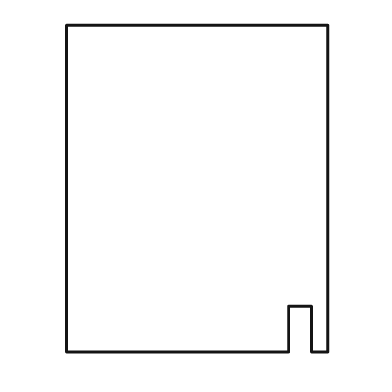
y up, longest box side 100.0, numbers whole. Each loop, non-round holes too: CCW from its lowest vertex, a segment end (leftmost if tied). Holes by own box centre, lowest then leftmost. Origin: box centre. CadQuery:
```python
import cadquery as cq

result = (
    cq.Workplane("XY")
    .moveTo(-40.0, -50.0)
    .lineTo(28.0, -50.0)
    .lineTo(28.0, -36.0)
    .lineTo(35.0, -36.0)
    .lineTo(35.0, -50.0)
    .lineTo(40.0, -50.0)
    .lineTo(40.0, 50.0)
    .lineTo(-40.0, 50.0)
    .close()
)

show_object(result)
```